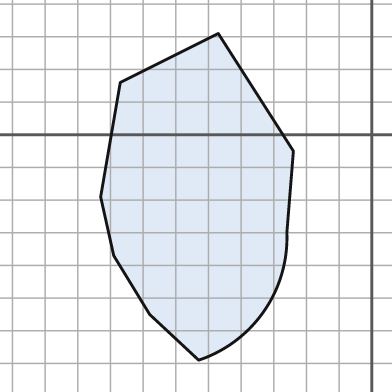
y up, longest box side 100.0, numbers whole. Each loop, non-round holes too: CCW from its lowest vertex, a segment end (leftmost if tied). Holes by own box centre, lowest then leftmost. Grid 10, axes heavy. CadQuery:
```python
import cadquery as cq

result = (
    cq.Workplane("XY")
    .moveTo(-53.0, -69.0)
    .threePointArc((-33.0, -54.0), (-26.0, -30.0))
    .lineTo(-24.0, -5.0)
    .lineTo(-47.0, 31.0)
    .lineTo(-77.0, 16.0)
    .lineTo(-83.0, -19.0)
    .lineTo(-79.0, -37.0)
    .lineTo(-68.0, -55.0)
    .close()
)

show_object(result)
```